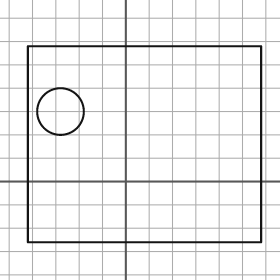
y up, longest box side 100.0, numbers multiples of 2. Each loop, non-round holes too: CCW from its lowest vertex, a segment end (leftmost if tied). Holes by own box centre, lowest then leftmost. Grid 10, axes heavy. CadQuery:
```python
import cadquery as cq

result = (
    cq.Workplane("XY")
    .moveTo(-42.0, -26.0)
    .lineTo(58.0, -26.0)
    .lineTo(58.0, 58.0)
    .lineTo(-42.0, 58.0)
    .close()
    .moveTo(-28.0, 30.0)
    .circle(10.0)
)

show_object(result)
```